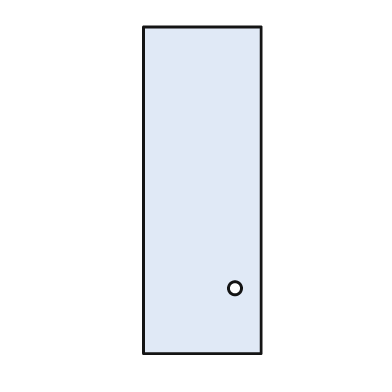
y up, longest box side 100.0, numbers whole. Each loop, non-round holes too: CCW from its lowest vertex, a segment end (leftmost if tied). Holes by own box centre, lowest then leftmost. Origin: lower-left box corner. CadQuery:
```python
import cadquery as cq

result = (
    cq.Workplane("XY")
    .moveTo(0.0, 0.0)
    .lineTo(36.0, 0.0)
    .lineTo(36.0, 100.0)
    .lineTo(0.0, 100.0)
    .close()
    .moveTo(28.0, 20.0)
    .circle(2.0)
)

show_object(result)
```